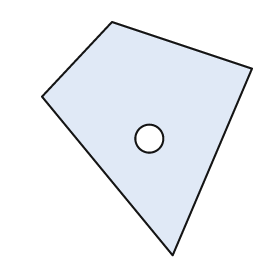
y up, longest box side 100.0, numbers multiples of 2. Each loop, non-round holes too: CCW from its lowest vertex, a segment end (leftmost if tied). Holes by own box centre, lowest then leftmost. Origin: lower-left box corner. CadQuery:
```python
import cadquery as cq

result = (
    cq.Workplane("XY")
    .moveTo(56.0, 0.0)
    .lineTo(90.0, 80.0)
    .lineTo(30.0, 100.0)
    .lineTo(0.0, 68.0)
    .close()
    .moveTo(46.0, 50.0)
    .circle(6.0)
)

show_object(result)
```